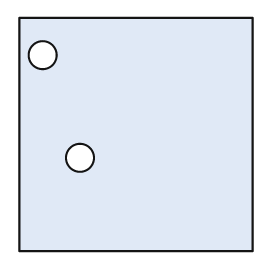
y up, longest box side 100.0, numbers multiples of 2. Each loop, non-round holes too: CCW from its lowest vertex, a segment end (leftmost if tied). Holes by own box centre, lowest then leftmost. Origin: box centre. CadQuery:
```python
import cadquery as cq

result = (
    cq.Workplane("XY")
    .moveTo(-50.0, -50.0)
    .lineTo(50.0, -50.0)
    .lineTo(50.0, 50.0)
    .lineTo(-50.0, 50.0)
    .close()
    .moveTo(-24.0, -10.0)
    .circle(6.0)
    .moveTo(-40.0, 34.0)
    .circle(6.0)
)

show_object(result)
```